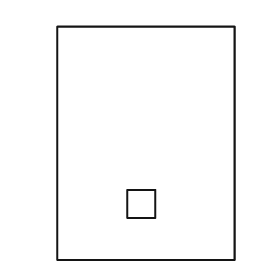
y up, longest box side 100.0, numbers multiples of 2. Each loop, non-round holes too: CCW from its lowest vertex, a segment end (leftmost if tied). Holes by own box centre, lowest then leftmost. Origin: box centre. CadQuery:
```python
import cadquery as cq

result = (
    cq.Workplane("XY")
    .moveTo(-38.0, -50.0)
    .lineTo(38.0, -50.0)
    .lineTo(38.0, 50.0)
    .lineTo(-38.0, 50.0)
    .close()
    .moveTo(-8.0, -32.0)
    .lineTo(4.0, -32.0)
    .lineTo(4.0, -20.0)
    .lineTo(-8.0, -20.0)
    .close()
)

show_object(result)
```